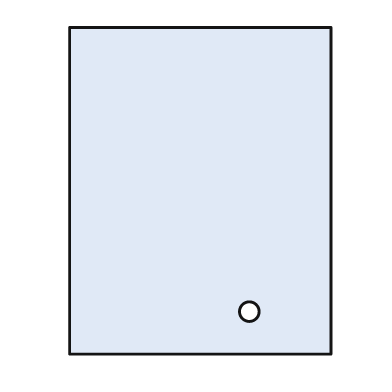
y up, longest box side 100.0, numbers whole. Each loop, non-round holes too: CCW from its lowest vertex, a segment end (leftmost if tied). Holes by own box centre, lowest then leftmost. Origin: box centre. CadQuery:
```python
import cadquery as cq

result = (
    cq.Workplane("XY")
    .moveTo(-40.0, -50.0)
    .lineTo(40.0, -50.0)
    .lineTo(40.0, 50.0)
    .lineTo(-40.0, 50.0)
    .close()
    .moveTo(15.0, -37.0)
    .circle(3.0)
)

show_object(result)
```